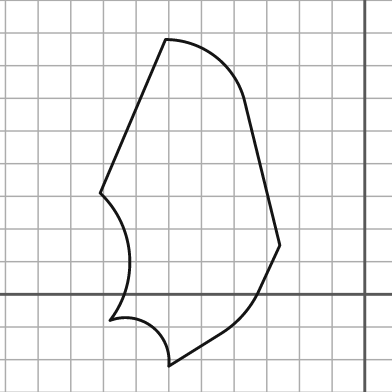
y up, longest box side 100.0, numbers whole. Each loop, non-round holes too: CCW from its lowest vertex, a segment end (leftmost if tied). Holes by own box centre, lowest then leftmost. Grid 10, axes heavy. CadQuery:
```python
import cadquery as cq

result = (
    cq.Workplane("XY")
    .moveTo(-60.0, -22.0)
    .lineTo(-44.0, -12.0)
    .threePointArc((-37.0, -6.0), (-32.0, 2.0))
    .lineTo(-26.0, 15.0)
    .lineTo(-37.0, 60.0)
    .threePointArc((-46.0, 73.0), (-61.0, 78.0))
    .lineTo(-81.0, 31.0)
    .threePointArc((-72.0, 12.0), (-78.0, -8.0))
    .threePointArc((-65.0, -10.0), (-60.0, -22.0))
    .close()
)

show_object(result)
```